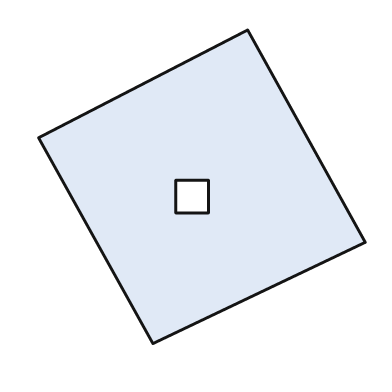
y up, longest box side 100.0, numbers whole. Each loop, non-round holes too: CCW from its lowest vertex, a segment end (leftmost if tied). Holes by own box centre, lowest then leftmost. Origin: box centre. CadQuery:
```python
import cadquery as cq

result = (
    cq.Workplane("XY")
    .moveTo(-15.0, -48.0)
    .lineTo(50.0, -17.0)
    .lineTo(14.0, 48.0)
    .lineTo(-50.0, 15.0)
    .close()
    .moveTo(-8.0, -8.0)
    .lineTo(2.0, -8.0)
    .lineTo(2.0, 2.0)
    .lineTo(-8.0, 2.0)
    .close()
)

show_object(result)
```